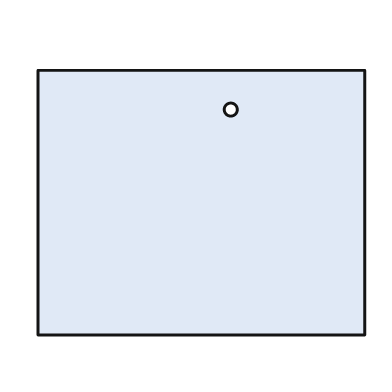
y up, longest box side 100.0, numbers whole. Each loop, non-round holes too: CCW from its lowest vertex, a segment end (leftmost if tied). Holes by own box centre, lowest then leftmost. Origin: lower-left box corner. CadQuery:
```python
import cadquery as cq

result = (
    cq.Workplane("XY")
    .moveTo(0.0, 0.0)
    .lineTo(100.0, 0.0)
    .lineTo(100.0, 81.0)
    .lineTo(0.0, 81.0)
    .close()
    .moveTo(59.0, 69.0)
    .circle(2.0)
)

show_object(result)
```